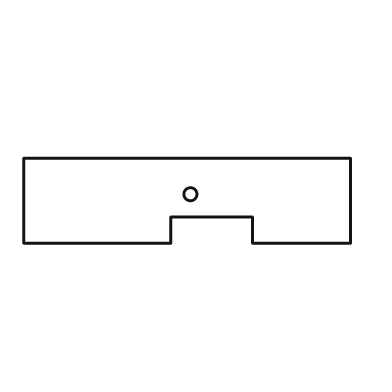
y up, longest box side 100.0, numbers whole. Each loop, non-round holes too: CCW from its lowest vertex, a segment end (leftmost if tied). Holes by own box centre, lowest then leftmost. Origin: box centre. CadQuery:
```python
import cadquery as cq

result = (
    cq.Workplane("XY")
    .moveTo(-50.0, -13.0)
    .lineTo(-5.0, -13.0)
    .lineTo(-5.0, -5.0)
    .lineTo(20.0, -5.0)
    .lineTo(20.0, -13.0)
    .lineTo(50.0, -13.0)
    .lineTo(50.0, 13.0)
    .lineTo(-50.0, 13.0)
    .close()
    .moveTo(1.0, 2.0)
    .circle(2.0)
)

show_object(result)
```